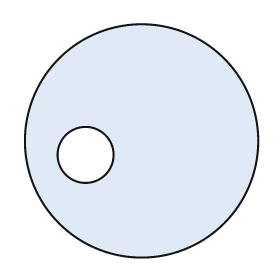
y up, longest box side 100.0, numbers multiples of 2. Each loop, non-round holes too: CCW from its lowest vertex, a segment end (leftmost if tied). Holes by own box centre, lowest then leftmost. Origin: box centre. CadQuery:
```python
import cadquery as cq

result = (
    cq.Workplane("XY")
    .moveTo(0.0, 0.0)
    .circle(50.0)
    .moveTo(-24.0, -6.0)
    .circle(12.0)
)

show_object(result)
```